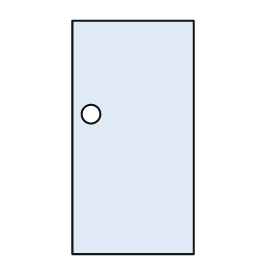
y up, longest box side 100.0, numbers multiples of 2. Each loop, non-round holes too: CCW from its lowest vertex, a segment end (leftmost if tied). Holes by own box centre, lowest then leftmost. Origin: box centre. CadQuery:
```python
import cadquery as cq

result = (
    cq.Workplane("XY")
    .moveTo(-26.0, -50.0)
    .lineTo(26.0, -50.0)
    .lineTo(26.0, 50.0)
    .lineTo(-26.0, 50.0)
    .close()
    .moveTo(-18.0, 10.0)
    .circle(4.0)
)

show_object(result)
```